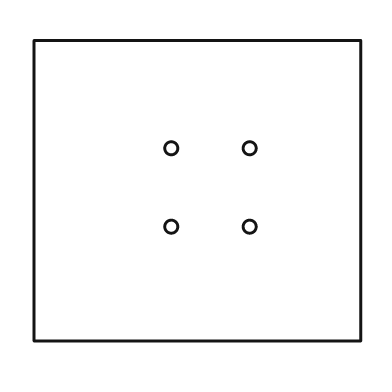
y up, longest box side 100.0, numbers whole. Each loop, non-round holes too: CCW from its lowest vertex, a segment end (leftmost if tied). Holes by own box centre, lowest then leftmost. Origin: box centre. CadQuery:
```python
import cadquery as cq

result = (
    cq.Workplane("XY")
    .moveTo(-50.0, -46.0)
    .lineTo(50.0, -46.0)
    .lineTo(50.0, 46.0)
    .lineTo(-50.0, 46.0)
    .close()
    .moveTo(-8.0, -11.0)
    .circle(2.0)
    .moveTo(16.0, -11.0)
    .circle(2.0)
    .moveTo(-8.0, 13.0)
    .circle(2.0)
    .moveTo(16.0, 13.0)
    .circle(2.0)
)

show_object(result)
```